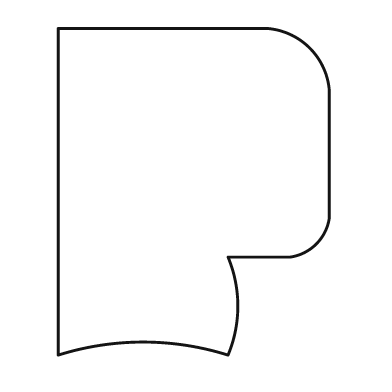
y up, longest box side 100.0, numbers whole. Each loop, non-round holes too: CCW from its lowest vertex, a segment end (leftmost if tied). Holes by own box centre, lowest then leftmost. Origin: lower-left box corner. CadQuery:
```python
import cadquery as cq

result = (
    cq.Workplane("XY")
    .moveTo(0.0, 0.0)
    .threePointArc((26.0, 4.0), (52.0, 0.0))
    .threePointArc((55.0, 15.0), (52.0, 30.0))
    .lineTo(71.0, 30.0)
    .threePointArc((79.0, 34.0), (83.0, 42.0))
    .lineTo(83.0, 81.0)
    .threePointArc((77.0, 94.0), (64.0, 100.0))
    .lineTo(0.0, 100.0)
    .close()
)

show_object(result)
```